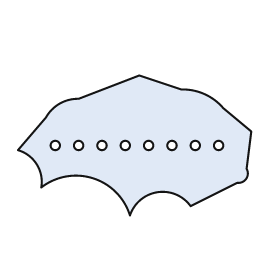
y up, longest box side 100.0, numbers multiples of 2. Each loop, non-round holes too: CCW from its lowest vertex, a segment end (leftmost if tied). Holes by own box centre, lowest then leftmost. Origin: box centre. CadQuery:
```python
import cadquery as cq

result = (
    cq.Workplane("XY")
    .moveTo(-2.0, -30.0)
    .threePointArc((10.0, -20.0), (24.0, -26.0))
    .lineTo(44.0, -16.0)
    .threePointArc((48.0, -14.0), (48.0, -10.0))
    .lineTo(50.0, 6.0)
    .lineTo(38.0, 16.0)
    .threePointArc((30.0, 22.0), (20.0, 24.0))
    .lineTo(2.0, 30.0)
    .lineTo(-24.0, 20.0)
    .threePointArc((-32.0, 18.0), (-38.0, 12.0))
    .lineTo(-50.0, -2.0)
    .threePointArc((-42.0, -8.0), (-40.0, -18.0))
    .threePointArc((-18.0, -14.0), (-2.0, -30.0))
    .close()
    .moveTo(-34.0, 0.0)
    .circle(2.0)
    .moveTo(-24.0, 0.0)
    .circle(2.0)
    .moveTo(-14.0, 0.0)
    .circle(2.0)
    .moveTo(-4.0, 0.0)
    .circle(2.0)
    .moveTo(6.0, 0.0)
    .circle(2.0)
    .moveTo(16.0, 0.0)
    .circle(2.0)
    .moveTo(26.0, 0.0)
    .circle(2.0)
    .moveTo(36.0, 0.0)
    .circle(2.0)
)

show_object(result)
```